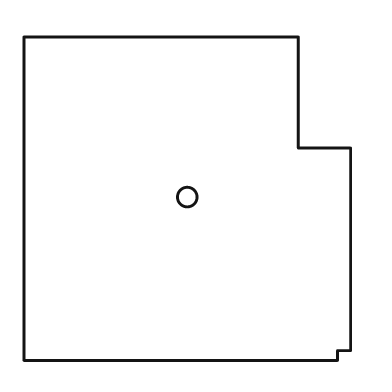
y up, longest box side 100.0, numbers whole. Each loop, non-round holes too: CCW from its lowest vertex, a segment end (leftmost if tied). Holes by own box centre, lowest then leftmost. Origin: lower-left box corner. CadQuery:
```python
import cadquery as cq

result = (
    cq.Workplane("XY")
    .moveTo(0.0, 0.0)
    .lineTo(96.0, 0.0)
    .lineTo(96.0, 3.0)
    .lineTo(100.0, 3.0)
    .lineTo(100.0, 65.0)
    .lineTo(84.0, 65.0)
    .lineTo(84.0, 99.0)
    .lineTo(0.0, 99.0)
    .close()
    .moveTo(50.0, 50.0)
    .circle(3.0)
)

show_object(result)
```